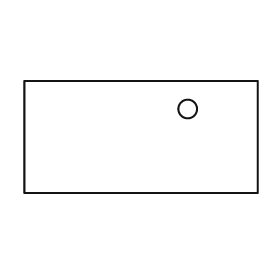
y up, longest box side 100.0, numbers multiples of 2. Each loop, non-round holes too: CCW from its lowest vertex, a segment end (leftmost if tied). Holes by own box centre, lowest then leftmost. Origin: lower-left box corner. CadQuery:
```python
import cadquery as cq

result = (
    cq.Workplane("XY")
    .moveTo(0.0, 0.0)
    .lineTo(100.0, 0.0)
    .lineTo(100.0, 48.0)
    .lineTo(0.0, 48.0)
    .close()
    .moveTo(70.0, 36.0)
    .circle(4.0)
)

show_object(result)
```